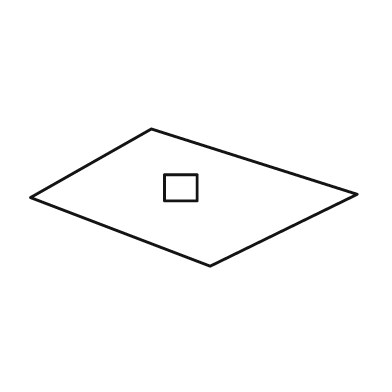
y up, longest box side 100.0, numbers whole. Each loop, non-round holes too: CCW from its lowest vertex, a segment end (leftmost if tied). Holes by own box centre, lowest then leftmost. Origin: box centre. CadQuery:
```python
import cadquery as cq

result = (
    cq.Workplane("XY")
    .moveTo(5.0, -21.0)
    .lineTo(50.0, 1.0)
    .lineTo(-13.0, 21.0)
    .lineTo(-50.0, 0.0)
    .close()
    .moveTo(-9.0, -1.0)
    .lineTo(1.0, -1.0)
    .lineTo(1.0, 7.0)
    .lineTo(-9.0, 7.0)
    .close()
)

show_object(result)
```